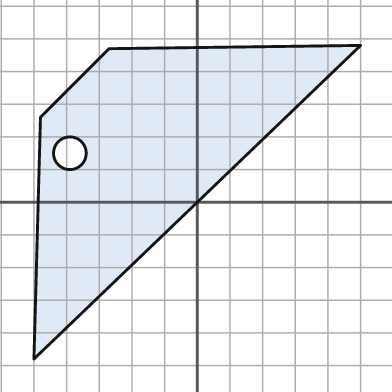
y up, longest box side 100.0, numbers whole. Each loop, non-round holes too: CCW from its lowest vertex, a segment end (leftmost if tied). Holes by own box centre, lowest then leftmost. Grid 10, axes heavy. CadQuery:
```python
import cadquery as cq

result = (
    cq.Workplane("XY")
    .moveTo(-50.0, -48.0)
    .lineTo(50.0, 48.0)
    .lineTo(-27.0, 47.0)
    .lineTo(-48.0, 26.0)
    .close()
    .moveTo(-39.0, 15.0)
    .circle(5.0)
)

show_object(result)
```